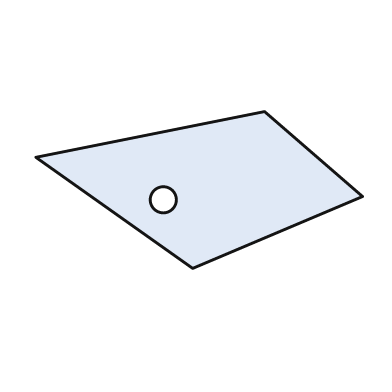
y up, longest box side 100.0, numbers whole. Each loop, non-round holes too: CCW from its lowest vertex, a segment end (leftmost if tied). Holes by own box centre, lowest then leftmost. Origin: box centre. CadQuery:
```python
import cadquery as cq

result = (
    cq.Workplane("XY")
    .moveTo(-2.0, -24.0)
    .lineTo(50.0, -2.0)
    .lineTo(20.0, 24.0)
    .lineTo(-50.0, 10.0)
    .close()
    .moveTo(-11.0, -3.0)
    .circle(4.0)
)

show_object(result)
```